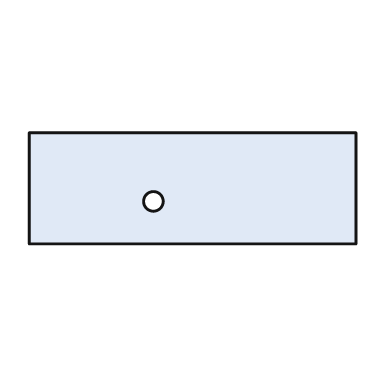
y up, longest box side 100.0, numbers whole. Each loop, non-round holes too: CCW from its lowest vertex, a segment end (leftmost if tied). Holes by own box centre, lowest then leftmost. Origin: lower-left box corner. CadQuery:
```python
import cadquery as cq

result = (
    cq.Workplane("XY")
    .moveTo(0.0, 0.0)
    .lineTo(100.0, 0.0)
    .lineTo(100.0, 34.0)
    .lineTo(0.0, 34.0)
    .close()
    .moveTo(38.0, 13.0)
    .circle(3.0)
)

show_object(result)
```